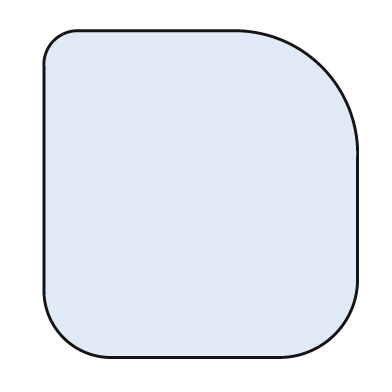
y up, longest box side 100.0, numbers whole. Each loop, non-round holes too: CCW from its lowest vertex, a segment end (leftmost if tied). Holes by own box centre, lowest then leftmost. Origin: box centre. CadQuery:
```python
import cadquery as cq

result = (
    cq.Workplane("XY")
    .moveTo(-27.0, -50.0)
    .lineTo(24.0, -50.0)
    .threePointArc((41.0, -43.0), (48.0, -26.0))
    .lineTo(48.0, 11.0)
    .threePointArc((37.0, 39.0), (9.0, 50.0))
    .lineTo(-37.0, 50.0)
    .threePointArc((-45.0, 47.0), (-48.0, 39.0))
    .lineTo(-48.0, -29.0)
    .threePointArc((-42.0, -44.0), (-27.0, -50.0))
    .close()
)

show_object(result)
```